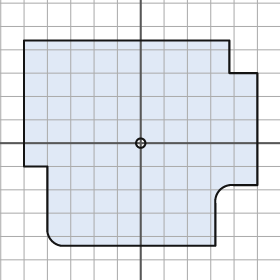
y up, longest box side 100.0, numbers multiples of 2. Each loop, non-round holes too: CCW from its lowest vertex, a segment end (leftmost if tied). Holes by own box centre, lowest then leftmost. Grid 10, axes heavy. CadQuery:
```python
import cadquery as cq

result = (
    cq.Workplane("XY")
    .moveTo(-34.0, -44.0)
    .lineTo(32.0, -44.0)
    .lineTo(32.0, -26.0)
    .threePointArc((34.0, -20.0), (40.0, -18.0))
    .lineTo(50.0, -18.0)
    .lineTo(50.0, 30.0)
    .lineTo(38.0, 30.0)
    .lineTo(38.0, 44.0)
    .lineTo(-50.0, 44.0)
    .lineTo(-50.0, -10.0)
    .lineTo(-40.0, -10.0)
    .lineTo(-40.0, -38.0)
    .threePointArc((-38.0, -42.0), (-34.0, -44.0))
    .close()
    .moveTo(0.0, 0.0)
    .circle(2.0)
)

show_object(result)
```